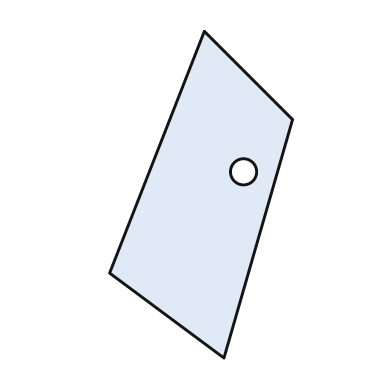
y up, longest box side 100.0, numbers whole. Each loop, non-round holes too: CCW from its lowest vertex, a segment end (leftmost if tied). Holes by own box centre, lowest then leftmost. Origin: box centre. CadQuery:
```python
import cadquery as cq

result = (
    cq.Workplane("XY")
    .moveTo(7.0, -50.0)
    .lineTo(28.0, 23.0)
    .lineTo(1.0, 50.0)
    .lineTo(-28.0, -24.0)
    .close()
    .moveTo(13.0, 7.0)
    .circle(4.0)
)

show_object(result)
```